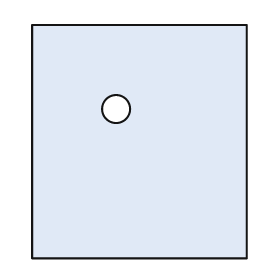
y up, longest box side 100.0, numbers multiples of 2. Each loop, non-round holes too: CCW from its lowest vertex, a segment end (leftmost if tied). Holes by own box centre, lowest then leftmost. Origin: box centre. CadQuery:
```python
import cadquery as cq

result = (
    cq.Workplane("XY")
    .moveTo(-46.0, -50.0)
    .lineTo(46.0, -50.0)
    .lineTo(46.0, 50.0)
    .lineTo(-46.0, 50.0)
    .close()
    .moveTo(-10.0, 14.0)
    .circle(6.0)
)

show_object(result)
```